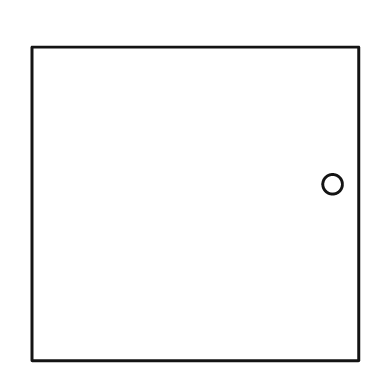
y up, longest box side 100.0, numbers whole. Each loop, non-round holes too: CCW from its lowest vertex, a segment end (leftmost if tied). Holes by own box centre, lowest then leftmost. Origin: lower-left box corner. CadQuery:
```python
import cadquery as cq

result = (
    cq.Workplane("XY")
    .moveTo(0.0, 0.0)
    .lineTo(100.0, 0.0)
    .lineTo(100.0, 96.0)
    .lineTo(0.0, 96.0)
    .close()
    .moveTo(92.0, 54.0)
    .circle(3.0)
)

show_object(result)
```